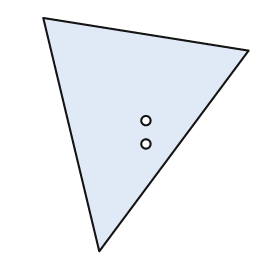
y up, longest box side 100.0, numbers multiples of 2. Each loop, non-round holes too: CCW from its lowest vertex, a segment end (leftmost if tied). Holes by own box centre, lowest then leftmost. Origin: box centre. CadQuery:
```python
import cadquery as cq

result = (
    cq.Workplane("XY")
    .moveTo(-20.0, -50.0)
    .lineTo(44.0, 36.0)
    .lineTo(-44.0, 50.0)
    .close()
    .moveTo(0.0, -4.0)
    .circle(2.0)
    .moveTo(0.0, 6.0)
    .circle(2.0)
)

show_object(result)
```